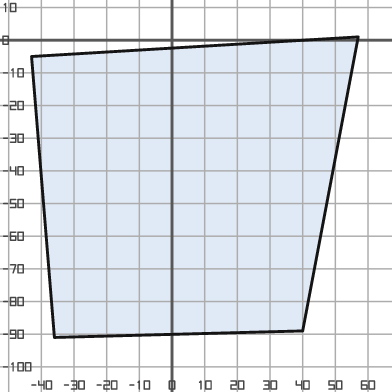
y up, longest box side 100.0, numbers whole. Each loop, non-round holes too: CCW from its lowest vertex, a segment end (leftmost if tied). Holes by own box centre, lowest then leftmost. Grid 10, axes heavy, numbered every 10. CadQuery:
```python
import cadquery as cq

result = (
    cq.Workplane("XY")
    .moveTo(-36.0, -91.0)
    .lineTo(40.0, -89.0)
    .lineTo(57.0, 1.0)
    .lineTo(-43.0, -5.0)
    .close()
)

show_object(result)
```